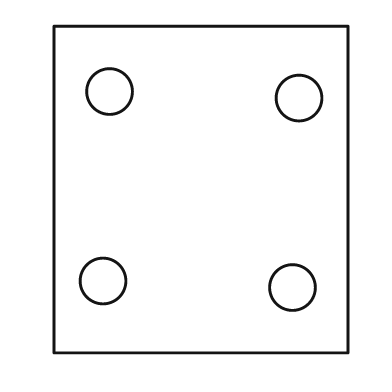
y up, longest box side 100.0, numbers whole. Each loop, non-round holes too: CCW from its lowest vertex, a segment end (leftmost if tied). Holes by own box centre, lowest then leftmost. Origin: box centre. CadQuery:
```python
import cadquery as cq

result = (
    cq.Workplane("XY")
    .moveTo(-45.0, -50.0)
    .lineTo(45.0, -50.0)
    .lineTo(45.0, 50.0)
    .lineTo(-45.0, 50.0)
    .close()
    .moveTo(28.0, -30.0)
    .circle(7.0)
    .moveTo(-30.0, -28.0)
    .circle(7.0)
    .moveTo(30.0, 28.0)
    .circle(7.0)
    .moveTo(-28.0, 30.0)
    .circle(7.0)
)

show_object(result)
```